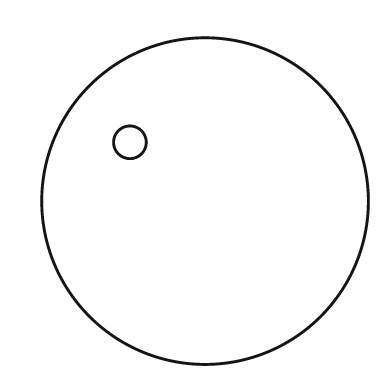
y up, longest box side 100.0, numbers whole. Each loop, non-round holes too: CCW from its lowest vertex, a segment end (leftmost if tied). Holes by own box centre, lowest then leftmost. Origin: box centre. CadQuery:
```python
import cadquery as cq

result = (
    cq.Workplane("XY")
    .moveTo(0.0, 0.0)
    .circle(50.0)
    .moveTo(-23.0, 18.0)
    .circle(5.0)
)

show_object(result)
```